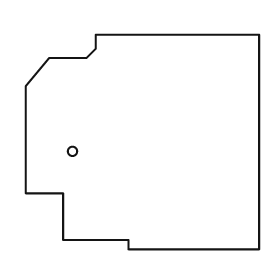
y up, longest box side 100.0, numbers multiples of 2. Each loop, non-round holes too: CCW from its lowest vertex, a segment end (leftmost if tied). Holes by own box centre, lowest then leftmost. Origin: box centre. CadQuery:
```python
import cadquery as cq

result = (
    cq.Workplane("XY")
    .moveTo(-6.0, -46.0)
    .lineTo(50.0, -46.0)
    .lineTo(50.0, 46.0)
    .lineTo(-20.0, 46.0)
    .lineTo(-20.0, 40.0)
    .lineTo(-24.0, 36.0)
    .lineTo(-40.0, 36.0)
    .lineTo(-50.0, 24.0)
    .lineTo(-50.0, -22.0)
    .lineTo(-34.0, -22.0)
    .lineTo(-34.0, -42.0)
    .lineTo(-6.0, -42.0)
    .close()
    .moveTo(-30.0, -4.0)
    .circle(2.0)
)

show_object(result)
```